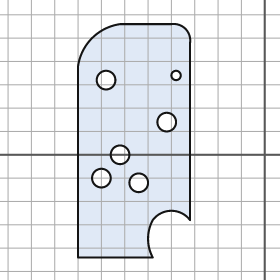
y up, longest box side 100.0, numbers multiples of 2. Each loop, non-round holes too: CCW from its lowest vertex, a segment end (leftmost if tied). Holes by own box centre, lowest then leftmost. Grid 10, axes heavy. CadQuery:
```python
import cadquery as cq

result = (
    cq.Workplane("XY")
    .moveTo(-80.0, -44.0)
    .lineTo(-48.0, -44.0)
    .threePointArc((-50.0, -36.0), (-48.0, -28.0))
    .threePointArc((-40.0, -24.0), (-32.0, -28.0))
    .lineTo(-32.0, 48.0)
    .threePointArc((-34.0, 54.0), (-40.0, 56.0))
    .lineTo(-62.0, 56.0)
    .threePointArc((-74.0, 50.0), (-80.0, 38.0))
    .close()
    .moveTo(-54.0, -12.0)
    .circle(4.0)
    .moveTo(-70.0, -10.0)
    .circle(4.0)
    .moveTo(-62.0, 0.0)
    .circle(4.0)
    .moveTo(-42.0, 14.0)
    .circle(4.0)
    .moveTo(-68.0, 32.0)
    .circle(4.0)
    .moveTo(-38.0, 34.0)
    .circle(2.0)
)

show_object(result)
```